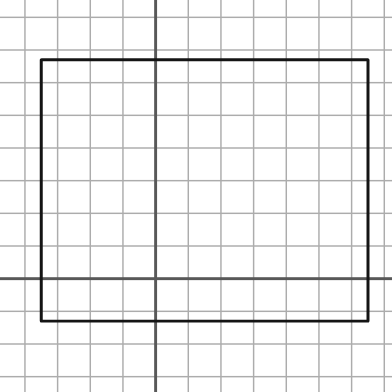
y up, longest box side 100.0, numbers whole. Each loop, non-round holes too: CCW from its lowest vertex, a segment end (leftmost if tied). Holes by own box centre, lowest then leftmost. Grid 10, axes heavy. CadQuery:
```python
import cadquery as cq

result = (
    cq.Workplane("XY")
    .moveTo(-35.0, -13.0)
    .lineTo(65.0, -13.0)
    .lineTo(65.0, 67.0)
    .lineTo(-35.0, 67.0)
    .close()
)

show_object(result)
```